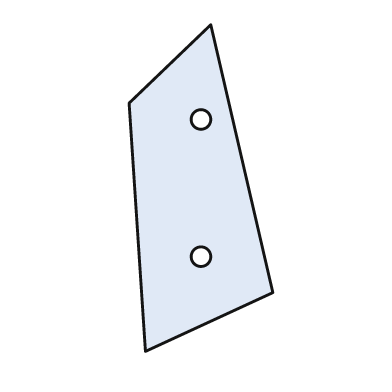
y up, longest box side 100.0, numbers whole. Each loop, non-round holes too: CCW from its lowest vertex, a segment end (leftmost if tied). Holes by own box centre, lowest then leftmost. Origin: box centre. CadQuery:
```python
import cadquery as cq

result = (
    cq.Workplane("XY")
    .moveTo(-17.0, -50.0)
    .lineTo(22.0, -32.0)
    .lineTo(3.0, 50.0)
    .lineTo(-22.0, 26.0)
    .close()
    .moveTo(0.0, -21.0)
    .circle(3.0)
    .moveTo(0.0, 21.0)
    .circle(3.0)
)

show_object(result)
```